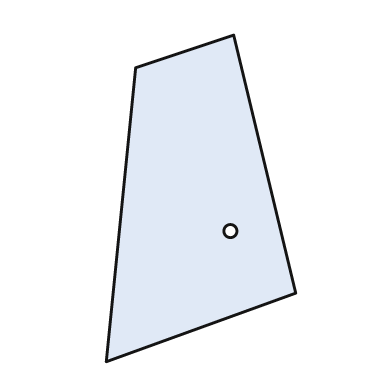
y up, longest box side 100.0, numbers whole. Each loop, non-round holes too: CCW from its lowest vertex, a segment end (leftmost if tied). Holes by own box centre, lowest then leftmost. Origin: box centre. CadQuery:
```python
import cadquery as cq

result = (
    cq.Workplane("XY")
    .moveTo(-29.0, -50.0)
    .lineTo(29.0, -29.0)
    .lineTo(10.0, 50.0)
    .lineTo(-20.0, 40.0)
    .close()
    .moveTo(9.0, -10.0)
    .circle(2.0)
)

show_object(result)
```